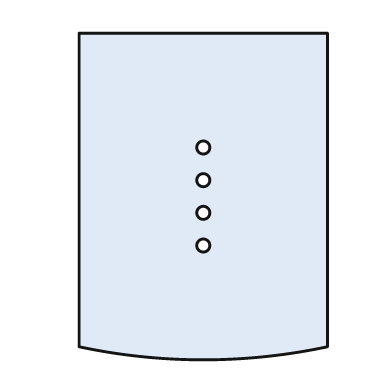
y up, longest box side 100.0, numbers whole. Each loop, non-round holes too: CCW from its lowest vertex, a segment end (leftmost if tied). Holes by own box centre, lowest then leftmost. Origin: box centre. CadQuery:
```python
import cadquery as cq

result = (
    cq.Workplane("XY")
    .moveTo(-38.0, -46.0)
    .threePointArc((0.0, -50.0), (38.0, -46.0))
    .lineTo(38.0, 50.0)
    .lineTo(-38.0, 50.0)
    .close()
    .moveTo(0.0, -15.0)
    .circle(2.0)
    .moveTo(0.0, -5.0)
    .circle(2.0)
    .moveTo(0.0, 5.0)
    .circle(2.0)
    .moveTo(0.0, 15.0)
    .circle(2.0)
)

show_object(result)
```